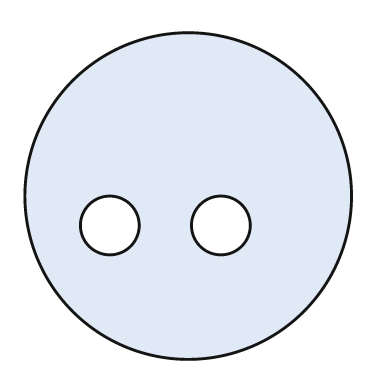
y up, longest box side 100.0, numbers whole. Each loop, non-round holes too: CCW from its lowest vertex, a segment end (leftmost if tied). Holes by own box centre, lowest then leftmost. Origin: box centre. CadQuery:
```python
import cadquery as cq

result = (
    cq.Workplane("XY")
    .moveTo(0.0, 0.0)
    .circle(50.0)
    .moveTo(-24.0, -9.0)
    .circle(9.0)
    .moveTo(10.0, -9.0)
    .circle(9.0)
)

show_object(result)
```